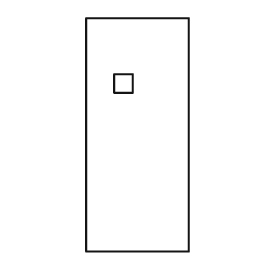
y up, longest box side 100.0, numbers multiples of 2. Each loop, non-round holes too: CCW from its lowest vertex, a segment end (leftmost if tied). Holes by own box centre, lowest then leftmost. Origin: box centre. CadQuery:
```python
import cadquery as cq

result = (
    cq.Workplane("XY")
    .moveTo(-22.0, -50.0)
    .lineTo(22.0, -50.0)
    .lineTo(22.0, 50.0)
    .lineTo(-22.0, 50.0)
    .close()
    .moveTo(-10.0, 18.0)
    .lineTo(-2.0, 18.0)
    .lineTo(-2.0, 26.0)
    .lineTo(-10.0, 26.0)
    .close()
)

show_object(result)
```